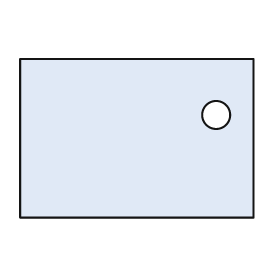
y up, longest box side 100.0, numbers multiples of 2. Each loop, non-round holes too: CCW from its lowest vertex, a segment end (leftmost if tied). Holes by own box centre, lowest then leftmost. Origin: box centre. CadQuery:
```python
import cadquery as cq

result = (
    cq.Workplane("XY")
    .moveTo(-50.0, -34.0)
    .lineTo(50.0, -34.0)
    .lineTo(50.0, 34.0)
    .lineTo(-50.0, 34.0)
    .close()
    .moveTo(34.0, 10.0)
    .circle(6.0)
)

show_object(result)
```